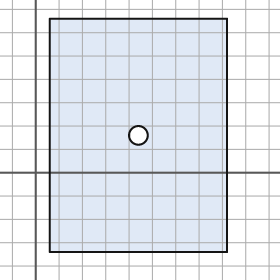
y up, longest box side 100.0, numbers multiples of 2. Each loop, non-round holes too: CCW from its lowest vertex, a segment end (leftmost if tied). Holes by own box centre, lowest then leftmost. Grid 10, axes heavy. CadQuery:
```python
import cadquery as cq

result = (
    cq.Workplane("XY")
    .moveTo(6.0, -34.0)
    .lineTo(82.0, -34.0)
    .lineTo(82.0, 66.0)
    .lineTo(6.0, 66.0)
    .close()
    .moveTo(44.0, 16.0)
    .circle(4.0)
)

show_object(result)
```